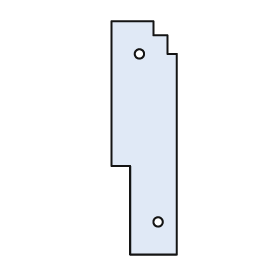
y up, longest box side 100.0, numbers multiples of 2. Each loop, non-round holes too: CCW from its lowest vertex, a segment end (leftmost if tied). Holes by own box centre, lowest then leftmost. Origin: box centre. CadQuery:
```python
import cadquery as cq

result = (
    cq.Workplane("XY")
    .moveTo(-6.0, -50.0)
    .lineTo(14.0, -50.0)
    .lineTo(14.0, 36.0)
    .lineTo(10.0, 36.0)
    .lineTo(10.0, 44.0)
    .lineTo(4.0, 44.0)
    .lineTo(4.0, 50.0)
    .lineTo(-14.0, 50.0)
    .lineTo(-14.0, -12.0)
    .lineTo(-6.0, -12.0)
    .close()
    .moveTo(6.0, -36.0)
    .circle(2.0)
    .moveTo(-2.0, 36.0)
    .circle(2.0)
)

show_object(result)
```